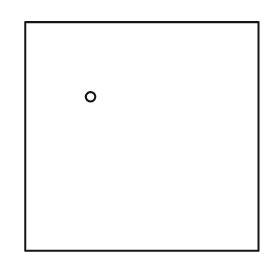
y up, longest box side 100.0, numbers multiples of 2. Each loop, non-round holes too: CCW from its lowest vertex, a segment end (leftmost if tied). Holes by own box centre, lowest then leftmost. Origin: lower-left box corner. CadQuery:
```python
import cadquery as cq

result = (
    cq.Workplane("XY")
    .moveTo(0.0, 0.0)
    .lineTo(100.0, 0.0)
    .lineTo(100.0, 98.0)
    .lineTo(0.0, 98.0)
    .close()
    .moveTo(28.0, 66.0)
    .circle(2.0)
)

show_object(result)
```